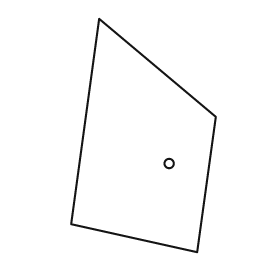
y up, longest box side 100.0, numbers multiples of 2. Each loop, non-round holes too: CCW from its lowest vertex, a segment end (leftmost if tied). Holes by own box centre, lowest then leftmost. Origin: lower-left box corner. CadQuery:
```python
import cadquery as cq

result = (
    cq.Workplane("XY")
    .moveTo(54.0, 0.0)
    .lineTo(62.0, 58.0)
    .lineTo(12.0, 100.0)
    .lineTo(0.0, 12.0)
    .close()
    .moveTo(42.0, 38.0)
    .circle(2.0)
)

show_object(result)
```